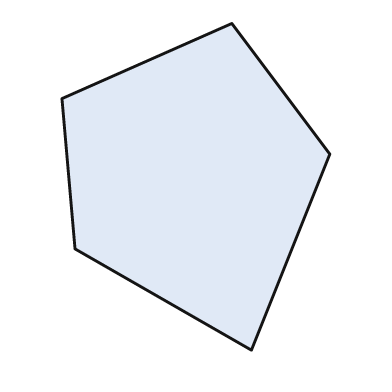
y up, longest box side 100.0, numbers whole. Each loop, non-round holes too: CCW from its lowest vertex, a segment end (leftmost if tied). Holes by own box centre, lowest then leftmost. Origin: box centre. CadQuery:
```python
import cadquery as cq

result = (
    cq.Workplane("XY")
    .moveTo(17.0, -50.0)
    .lineTo(41.0, 10.0)
    .lineTo(11.0, 50.0)
    .lineTo(-41.0, 27.0)
    .lineTo(-37.0, -19.0)
    .close()
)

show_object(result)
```